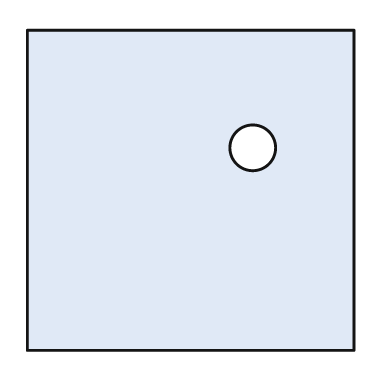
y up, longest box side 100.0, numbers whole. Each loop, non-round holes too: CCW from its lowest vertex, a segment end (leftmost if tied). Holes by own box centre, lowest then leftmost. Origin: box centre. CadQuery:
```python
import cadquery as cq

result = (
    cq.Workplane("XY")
    .moveTo(-50.0, -49.0)
    .lineTo(50.0, -49.0)
    .lineTo(50.0, 49.0)
    .lineTo(-50.0, 49.0)
    .close()
    .moveTo(19.0, 13.0)
    .circle(7.0)
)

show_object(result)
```